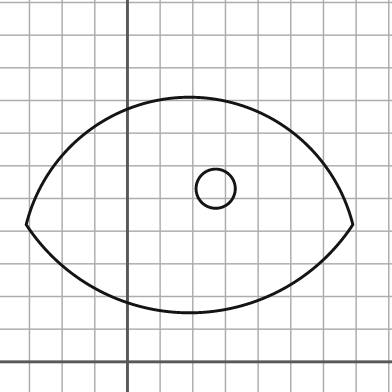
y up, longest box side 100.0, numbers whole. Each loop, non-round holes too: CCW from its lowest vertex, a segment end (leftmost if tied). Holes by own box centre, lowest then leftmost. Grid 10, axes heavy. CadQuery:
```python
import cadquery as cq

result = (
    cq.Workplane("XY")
    .moveTo(-31.0, 42.0)
    .threePointArc((19.0, 15.0), (69.0, 42.0))
    .threePointArc((19.0, 81.0), (-31.0, 42.0))
    .close()
    .moveTo(27.0, 53.0)
    .circle(6.0)
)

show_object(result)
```